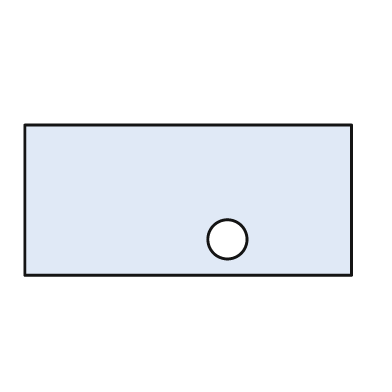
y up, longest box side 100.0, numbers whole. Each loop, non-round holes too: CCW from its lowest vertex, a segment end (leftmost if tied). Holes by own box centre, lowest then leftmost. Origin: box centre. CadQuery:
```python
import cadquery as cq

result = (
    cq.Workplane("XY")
    .moveTo(-50.0, -23.0)
    .lineTo(50.0, -23.0)
    .lineTo(50.0, 23.0)
    .lineTo(-50.0, 23.0)
    .close()
    .moveTo(12.0, -12.0)
    .circle(6.0)
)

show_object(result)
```